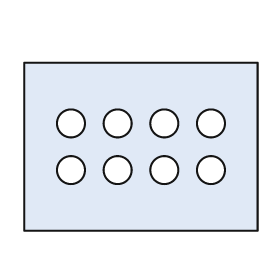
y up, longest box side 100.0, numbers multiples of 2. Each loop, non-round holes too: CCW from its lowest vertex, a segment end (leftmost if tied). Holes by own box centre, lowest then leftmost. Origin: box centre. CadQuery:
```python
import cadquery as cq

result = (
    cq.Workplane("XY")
    .moveTo(-50.0, -36.0)
    .lineTo(50.0, -36.0)
    .lineTo(50.0, 36.0)
    .lineTo(-50.0, 36.0)
    .close()
    .moveTo(-30.0, -10.0)
    .circle(6.0)
    .moveTo(-10.0, -10.0)
    .circle(6.0)
    .moveTo(10.0, -10.0)
    .circle(6.0)
    .moveTo(30.0, -10.0)
    .circle(6.0)
    .moveTo(-30.0, 10.0)
    .circle(6.0)
    .moveTo(-10.0, 10.0)
    .circle(6.0)
    .moveTo(10.0, 10.0)
    .circle(6.0)
    .moveTo(30.0, 10.0)
    .circle(6.0)
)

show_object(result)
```